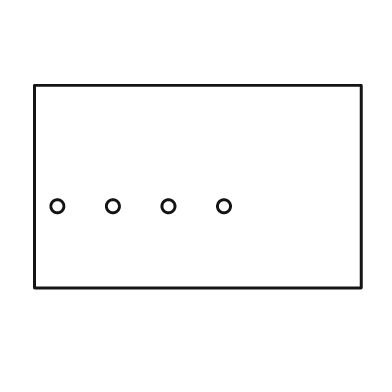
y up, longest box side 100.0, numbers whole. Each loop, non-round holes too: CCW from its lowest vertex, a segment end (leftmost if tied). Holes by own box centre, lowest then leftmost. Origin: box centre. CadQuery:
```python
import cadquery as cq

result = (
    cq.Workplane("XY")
    .moveTo(-50.0, -31.0)
    .lineTo(50.0, -31.0)
    .lineTo(50.0, 31.0)
    .lineTo(-50.0, 31.0)
    .close()
    .moveTo(-43.0, -6.0)
    .circle(2.0)
    .moveTo(-26.0, -6.0)
    .circle(2.0)
    .moveTo(-9.0, -6.0)
    .circle(2.0)
    .moveTo(8.0, -6.0)
    .circle(2.0)
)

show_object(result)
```